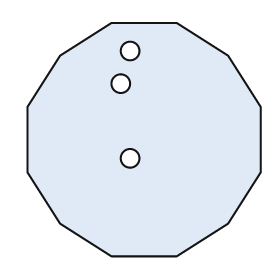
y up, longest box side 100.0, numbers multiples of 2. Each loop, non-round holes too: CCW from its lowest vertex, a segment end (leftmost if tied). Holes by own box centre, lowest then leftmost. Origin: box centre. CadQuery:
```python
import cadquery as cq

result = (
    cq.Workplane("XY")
    .moveTo(-14.0, -50.0)
    .lineTo(14.0, -50.0)
    .lineTo(36.0, -36.0)
    .lineTo(50.0, -14.0)
    .lineTo(50.0, 14.0)
    .lineTo(36.0, 36.0)
    .lineTo(14.0, 50.0)
    .lineTo(-14.0, 50.0)
    .lineTo(-36.0, 36.0)
    .lineTo(-50.0, 14.0)
    .lineTo(-50.0, -14.0)
    .lineTo(-36.0, -36.0)
    .close()
    .moveTo(-6.0, -8.0)
    .circle(4.0)
    .moveTo(-10.0, 24.0)
    .circle(4.0)
    .moveTo(-6.0, 38.0)
    .circle(4.0)
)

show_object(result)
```